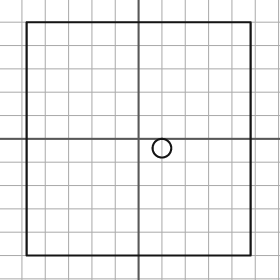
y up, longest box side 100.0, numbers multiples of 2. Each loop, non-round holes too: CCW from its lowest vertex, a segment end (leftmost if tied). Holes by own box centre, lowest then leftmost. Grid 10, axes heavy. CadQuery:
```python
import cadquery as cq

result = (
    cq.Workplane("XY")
    .moveTo(-48.0, -50.0)
    .lineTo(48.0, -50.0)
    .lineTo(48.0, 50.0)
    .lineTo(-48.0, 50.0)
    .close()
    .moveTo(10.0, -4.0)
    .circle(4.0)
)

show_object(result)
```